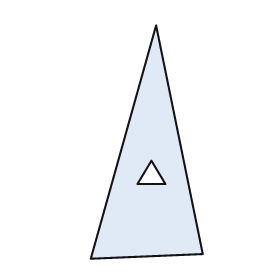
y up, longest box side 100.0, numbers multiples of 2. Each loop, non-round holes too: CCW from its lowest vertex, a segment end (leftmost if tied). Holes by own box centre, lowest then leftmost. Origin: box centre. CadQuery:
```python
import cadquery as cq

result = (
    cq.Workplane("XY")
    .moveTo(-24.0, -50.0)
    .lineTo(24.0, -48.0)
    .lineTo(4.0, 50.0)
    .close()
    .moveTo(-4.0, -18.0)
    .lineTo(8.0, -18.0)
    .lineTo(2.0, -8.0)
    .close()
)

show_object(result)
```